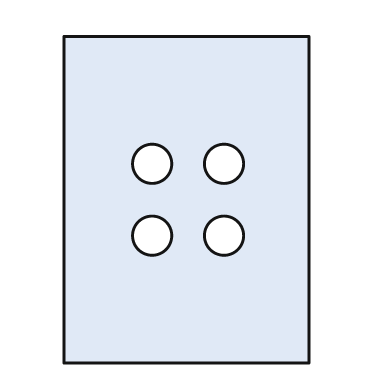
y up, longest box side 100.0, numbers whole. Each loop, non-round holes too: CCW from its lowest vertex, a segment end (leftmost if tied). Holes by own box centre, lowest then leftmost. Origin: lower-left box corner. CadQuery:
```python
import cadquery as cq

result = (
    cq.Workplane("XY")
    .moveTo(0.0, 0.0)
    .lineTo(75.0, 0.0)
    .lineTo(75.0, 100.0)
    .lineTo(0.0, 100.0)
    .close()
    .moveTo(27.0, 39.0)
    .circle(6.0)
    .moveTo(49.0, 39.0)
    .circle(6.0)
    .moveTo(27.0, 61.0)
    .circle(6.0)
    .moveTo(49.0, 61.0)
    .circle(6.0)
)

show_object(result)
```